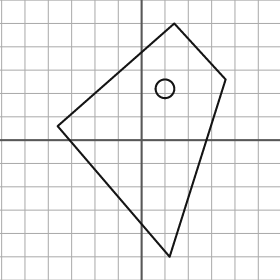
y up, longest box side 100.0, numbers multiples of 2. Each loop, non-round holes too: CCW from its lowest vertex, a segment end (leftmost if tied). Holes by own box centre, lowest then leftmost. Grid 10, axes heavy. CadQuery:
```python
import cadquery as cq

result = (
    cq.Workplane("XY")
    .moveTo(12.0, -50.0)
    .lineTo(36.0, 26.0)
    .lineTo(14.0, 50.0)
    .lineTo(-36.0, 6.0)
    .close()
    .moveTo(10.0, 22.0)
    .circle(4.0)
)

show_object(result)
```